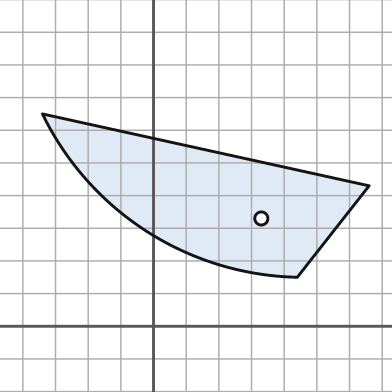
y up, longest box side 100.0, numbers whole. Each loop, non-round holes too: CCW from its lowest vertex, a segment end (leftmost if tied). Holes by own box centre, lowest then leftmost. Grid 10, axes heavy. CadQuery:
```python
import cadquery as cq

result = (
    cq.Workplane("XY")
    .moveTo(44.0, 15.0)
    .lineTo(66.0, 43.0)
    .lineTo(-34.0, 65.0)
    .threePointArc((-2.0, 29.0), (44.0, 15.0))
    .close()
    .moveTo(33.0, 33.0)
    .circle(2.0)
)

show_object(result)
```